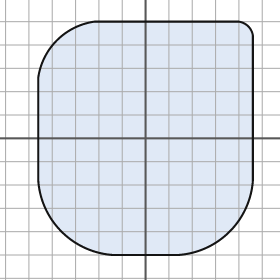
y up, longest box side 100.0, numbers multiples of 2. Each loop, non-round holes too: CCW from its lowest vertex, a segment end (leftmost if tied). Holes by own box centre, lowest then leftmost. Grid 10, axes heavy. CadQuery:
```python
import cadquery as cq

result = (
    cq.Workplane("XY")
    .moveTo(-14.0, -50.0)
    .lineTo(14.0, -50.0)
    .threePointArc((36.0, -40.0), (46.0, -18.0))
    .lineTo(46.0, 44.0)
    .threePointArc((44.0, 48.0), (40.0, 50.0))
    .lineTo(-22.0, 50.0)
    .threePointArc((-38.0, 42.0), (-46.0, 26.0))
    .lineTo(-46.0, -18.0)
    .threePointArc((-36.0, -40.0), (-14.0, -50.0))
    .close()
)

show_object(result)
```